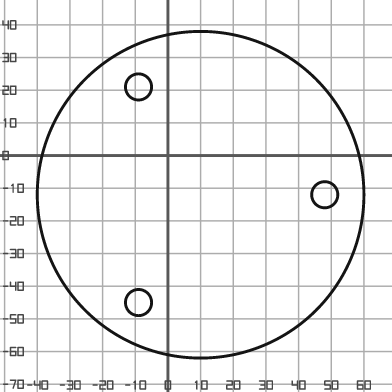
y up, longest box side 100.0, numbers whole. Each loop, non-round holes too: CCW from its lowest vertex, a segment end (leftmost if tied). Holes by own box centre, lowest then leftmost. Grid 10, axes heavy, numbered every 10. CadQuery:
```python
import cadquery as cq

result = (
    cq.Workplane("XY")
    .moveTo(10.0, -12.0)
    .circle(50.0)
    .moveTo(-9.0, -45.0)
    .circle(4.0)
    .moveTo(48.0, -12.0)
    .circle(4.0)
    .moveTo(-9.0, 21.0)
    .circle(4.0)
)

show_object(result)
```